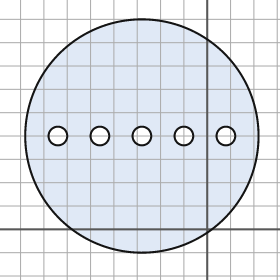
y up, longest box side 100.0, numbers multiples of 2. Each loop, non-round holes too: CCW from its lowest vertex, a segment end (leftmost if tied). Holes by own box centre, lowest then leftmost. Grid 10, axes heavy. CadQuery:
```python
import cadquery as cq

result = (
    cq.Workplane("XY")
    .moveTo(-28.0, 40.0)
    .circle(50.0)
    .moveTo(-64.0, 40.0)
    .circle(4.0)
    .moveTo(-46.0, 40.0)
    .circle(4.0)
    .moveTo(-28.0, 40.0)
    .circle(4.0)
    .moveTo(-10.0, 40.0)
    .circle(4.0)
    .moveTo(8.0, 40.0)
    .circle(4.0)
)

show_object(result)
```